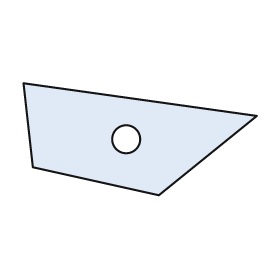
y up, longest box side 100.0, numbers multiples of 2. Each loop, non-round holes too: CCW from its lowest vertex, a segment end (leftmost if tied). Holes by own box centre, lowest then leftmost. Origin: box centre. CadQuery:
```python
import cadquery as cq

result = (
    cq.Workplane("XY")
    .moveTo(8.0, -24.0)
    .lineTo(50.0, 10.0)
    .lineTo(-50.0, 24.0)
    .lineTo(-46.0, -12.0)
    .close()
    .moveTo(-6.0, 0.0)
    .circle(6.0)
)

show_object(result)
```